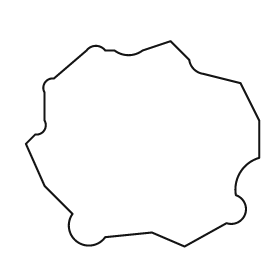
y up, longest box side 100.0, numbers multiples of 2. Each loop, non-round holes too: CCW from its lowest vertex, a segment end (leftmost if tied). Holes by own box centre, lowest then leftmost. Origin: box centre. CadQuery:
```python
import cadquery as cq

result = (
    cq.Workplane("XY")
    .moveTo(18.0, -44.0)
    .lineTo(36.0, -34.0)
    .threePointArc((44.0, -30.0), (40.0, -22.0))
    .threePointArc((42.0, -12.0), (50.0, -6.0))
    .lineTo(50.0, 10.0)
    .lineTo(42.0, 26.0)
    .lineTo(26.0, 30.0)
    .threePointArc((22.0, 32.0), (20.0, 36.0))
    .lineTo(12.0, 44.0)
    .lineTo(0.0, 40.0)
    .threePointArc((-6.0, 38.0), (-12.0, 40.0))
    .lineTo(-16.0, 40.0)
    .threePointArc((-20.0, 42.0), (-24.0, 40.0))
    .lineTo(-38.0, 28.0)
    .threePointArc((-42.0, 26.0), (-42.0, 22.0))
    .lineTo(-42.0, 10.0)
    .threePointArc((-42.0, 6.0), (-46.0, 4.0))
    .lineTo(-50.0, 0.0)
    .lineTo(-42.0, -18.0)
    .lineTo(-30.0, -30.0)
    .threePointArc((-28.0, -42.0), (-16.0, -40.0))
    .lineTo(4.0, -38.0)
    .close()
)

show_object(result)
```